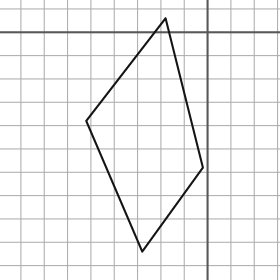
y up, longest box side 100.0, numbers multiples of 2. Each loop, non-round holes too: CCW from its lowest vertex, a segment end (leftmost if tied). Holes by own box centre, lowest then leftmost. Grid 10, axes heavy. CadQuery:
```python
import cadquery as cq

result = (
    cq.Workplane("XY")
    .moveTo(-28.0, -94.0)
    .lineTo(-2.0, -58.0)
    .lineTo(-18.0, 6.0)
    .lineTo(-52.0, -38.0)
    .close()
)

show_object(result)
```